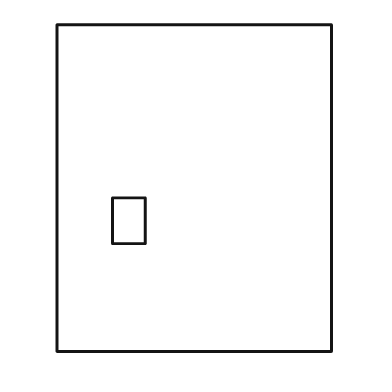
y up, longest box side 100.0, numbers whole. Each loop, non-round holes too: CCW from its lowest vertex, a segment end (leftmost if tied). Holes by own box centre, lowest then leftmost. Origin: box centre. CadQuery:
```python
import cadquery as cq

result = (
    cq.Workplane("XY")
    .moveTo(-42.0, -50.0)
    .lineTo(42.0, -50.0)
    .lineTo(42.0, 50.0)
    .lineTo(-42.0, 50.0)
    .close()
    .moveTo(-25.0, -17.0)
    .lineTo(-15.0, -17.0)
    .lineTo(-15.0, -3.0)
    .lineTo(-25.0, -3.0)
    .close()
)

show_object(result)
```